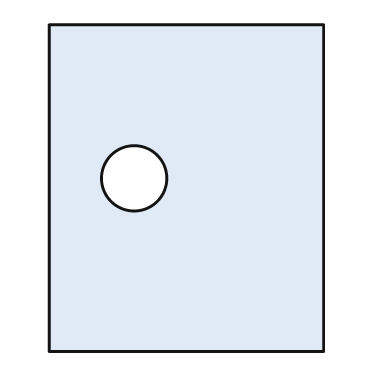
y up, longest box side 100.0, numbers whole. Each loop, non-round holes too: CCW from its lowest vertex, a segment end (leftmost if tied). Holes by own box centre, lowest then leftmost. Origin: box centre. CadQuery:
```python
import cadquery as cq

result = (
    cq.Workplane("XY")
    .moveTo(-42.0, -50.0)
    .lineTo(42.0, -50.0)
    .lineTo(42.0, 50.0)
    .lineTo(-42.0, 50.0)
    .close()
    .moveTo(-16.0, 3.0)
    .circle(10.0)
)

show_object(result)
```